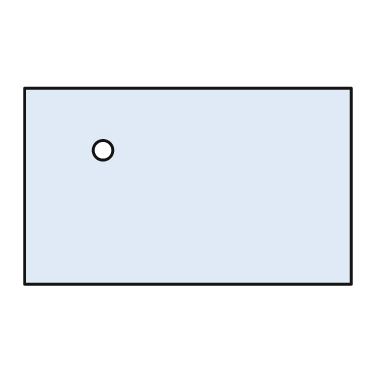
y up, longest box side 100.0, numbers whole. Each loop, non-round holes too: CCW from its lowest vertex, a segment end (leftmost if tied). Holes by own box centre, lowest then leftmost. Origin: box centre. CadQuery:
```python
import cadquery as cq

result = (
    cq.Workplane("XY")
    .moveTo(-50.0, -30.0)
    .lineTo(50.0, -30.0)
    .lineTo(50.0, 30.0)
    .lineTo(-50.0, 30.0)
    .close()
    .moveTo(-26.0, 11.0)
    .circle(3.0)
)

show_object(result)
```